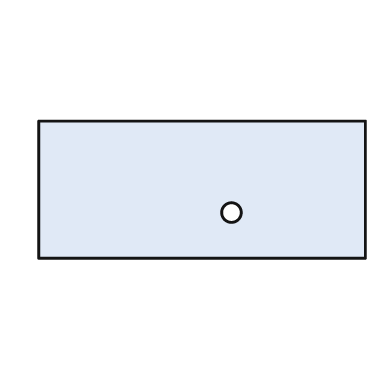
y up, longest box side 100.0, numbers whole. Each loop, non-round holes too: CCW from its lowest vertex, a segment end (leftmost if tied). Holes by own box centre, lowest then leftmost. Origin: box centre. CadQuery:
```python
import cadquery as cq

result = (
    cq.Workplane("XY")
    .moveTo(-50.0, -21.0)
    .lineTo(50.0, -21.0)
    .lineTo(50.0, 21.0)
    .lineTo(-50.0, 21.0)
    .close()
    .moveTo(9.0, -7.0)
    .circle(3.0)
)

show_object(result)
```